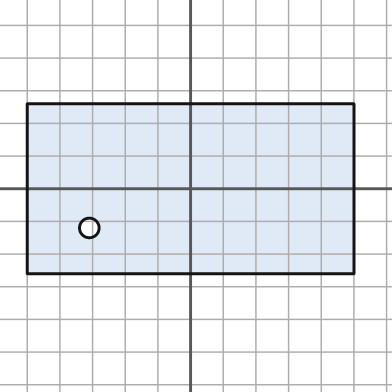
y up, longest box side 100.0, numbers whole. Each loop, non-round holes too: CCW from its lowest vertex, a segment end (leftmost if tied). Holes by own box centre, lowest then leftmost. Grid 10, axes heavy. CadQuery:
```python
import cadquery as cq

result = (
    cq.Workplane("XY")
    .moveTo(-50.0, -26.0)
    .lineTo(50.0, -26.0)
    .lineTo(50.0, 26.0)
    .lineTo(-50.0, 26.0)
    .close()
    .moveTo(-31.0, -12.0)
    .circle(3.0)
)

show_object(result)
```